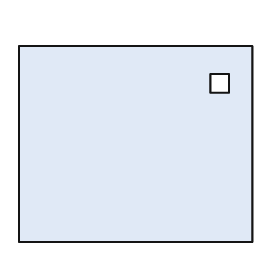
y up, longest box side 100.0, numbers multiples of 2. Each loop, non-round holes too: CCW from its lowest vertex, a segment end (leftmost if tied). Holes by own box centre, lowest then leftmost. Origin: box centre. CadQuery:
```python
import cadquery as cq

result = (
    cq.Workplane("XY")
    .moveTo(-50.0, -42.0)
    .lineTo(50.0, -42.0)
    .lineTo(50.0, 42.0)
    .lineTo(-50.0, 42.0)
    .close()
    .moveTo(32.0, 22.0)
    .lineTo(40.0, 22.0)
    .lineTo(40.0, 30.0)
    .lineTo(32.0, 30.0)
    .close()
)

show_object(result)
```